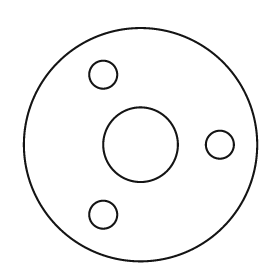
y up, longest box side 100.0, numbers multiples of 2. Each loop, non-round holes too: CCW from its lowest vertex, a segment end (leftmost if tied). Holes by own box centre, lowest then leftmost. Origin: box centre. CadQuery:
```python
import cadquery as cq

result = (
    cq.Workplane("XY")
    .moveTo(0.0, 0.0)
    .circle(50.0)
    .moveTo(-16.0, -30.0)
    .circle(6.0)
    .moveTo(0.0, 0.0)
    .circle(16.0)
    .moveTo(34.0, 0.0)
    .circle(6.0)
    .moveTo(-16.0, 30.0)
    .circle(6.0)
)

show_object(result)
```